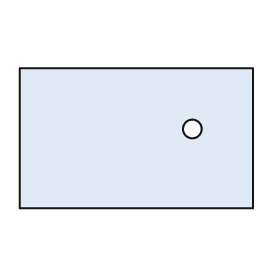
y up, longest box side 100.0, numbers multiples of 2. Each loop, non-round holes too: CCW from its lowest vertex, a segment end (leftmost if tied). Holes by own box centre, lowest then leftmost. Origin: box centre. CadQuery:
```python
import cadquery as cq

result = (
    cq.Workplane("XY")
    .moveTo(-50.0, -30.0)
    .lineTo(50.0, -30.0)
    .lineTo(50.0, 30.0)
    .lineTo(-50.0, 30.0)
    .close()
    .moveTo(24.0, 4.0)
    .circle(4.0)
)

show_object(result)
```